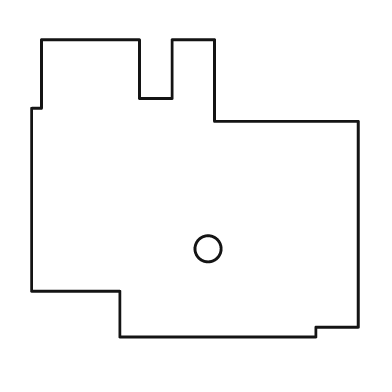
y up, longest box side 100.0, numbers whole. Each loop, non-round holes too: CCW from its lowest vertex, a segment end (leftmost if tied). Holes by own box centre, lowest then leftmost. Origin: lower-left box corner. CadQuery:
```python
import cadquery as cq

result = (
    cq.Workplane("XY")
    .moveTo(27.0, 0.0)
    .lineTo(87.0, 0.0)
    .lineTo(87.0, 3.0)
    .lineTo(100.0, 3.0)
    .lineTo(100.0, 66.0)
    .lineTo(56.0, 66.0)
    .lineTo(56.0, 91.0)
    .lineTo(43.0, 91.0)
    .lineTo(43.0, 73.0)
    .lineTo(33.0, 73.0)
    .lineTo(33.0, 91.0)
    .lineTo(3.0, 91.0)
    .lineTo(3.0, 70.0)
    .lineTo(0.0, 70.0)
    .lineTo(0.0, 14.0)
    .lineTo(27.0, 14.0)
    .close()
    .moveTo(54.0, 27.0)
    .circle(4.0)
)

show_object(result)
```